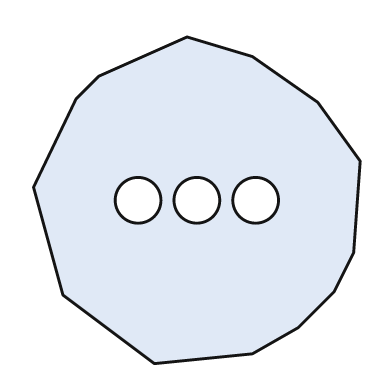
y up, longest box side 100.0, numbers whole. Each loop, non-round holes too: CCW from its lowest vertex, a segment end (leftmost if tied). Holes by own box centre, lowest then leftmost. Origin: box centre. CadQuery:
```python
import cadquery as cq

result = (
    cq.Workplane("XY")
    .moveTo(-13.0, -50.0)
    .lineTo(17.0, -47.0)
    .lineTo(31.0, -39.0)
    .lineTo(42.0, -28.0)
    .lineTo(48.0, -16.0)
    .lineTo(50.0, 12.0)
    .lineTo(37.0, 30.0)
    .lineTo(17.0, 44.0)
    .lineTo(-3.0, 50.0)
    .lineTo(-30.0, 38.0)
    .lineTo(-37.0, 31.0)
    .lineTo(-50.0, 4.0)
    .lineTo(-41.0, -29.0)
    .close()
    .moveTo(-18.0, 0.0)
    .circle(7.0)
    .moveTo(0.0, 0.0)
    .circle(7.0)
    .moveTo(18.0, 0.0)
    .circle(7.0)
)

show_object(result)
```